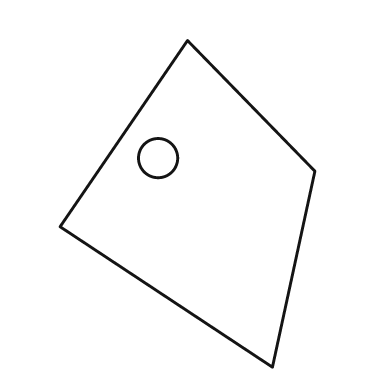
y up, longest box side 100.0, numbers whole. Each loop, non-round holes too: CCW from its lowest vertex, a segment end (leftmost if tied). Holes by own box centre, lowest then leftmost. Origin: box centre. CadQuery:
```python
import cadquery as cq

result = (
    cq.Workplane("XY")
    .moveTo(26.0, -50.0)
    .lineTo(39.0, 10.0)
    .lineTo(0.0, 50.0)
    .lineTo(-39.0, -7.0)
    .close()
    .moveTo(-9.0, 14.0)
    .circle(6.0)
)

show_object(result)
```